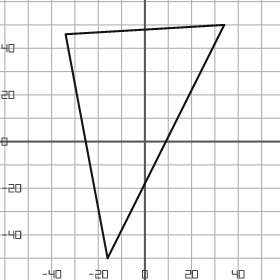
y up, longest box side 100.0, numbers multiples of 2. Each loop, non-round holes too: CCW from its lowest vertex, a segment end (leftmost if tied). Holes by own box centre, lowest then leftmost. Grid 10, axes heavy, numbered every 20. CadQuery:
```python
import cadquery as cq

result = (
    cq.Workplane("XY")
    .moveTo(-16.0, -50.0)
    .lineTo(34.0, 50.0)
    .lineTo(-34.0, 46.0)
    .close()
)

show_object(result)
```